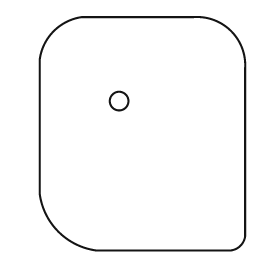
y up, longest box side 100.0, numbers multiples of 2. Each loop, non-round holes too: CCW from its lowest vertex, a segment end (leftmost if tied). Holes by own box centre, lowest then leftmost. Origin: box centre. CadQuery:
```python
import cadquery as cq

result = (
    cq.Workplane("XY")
    .moveTo(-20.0, -50.0)
    .lineTo(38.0, -50.0)
    .threePointArc((42.0, -48.0), (44.0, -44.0))
    .lineTo(44.0, 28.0)
    .threePointArc((38.0, 44.0), (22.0, 50.0))
    .lineTo(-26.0, 50.0)
    .threePointArc((-38.0, 44.0), (-44.0, 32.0))
    .lineTo(-44.0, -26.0)
    .threePointArc((-36.0, -42.0), (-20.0, -50.0))
    .close()
    .moveTo(-10.0, 14.0)
    .circle(4.0)
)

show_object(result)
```